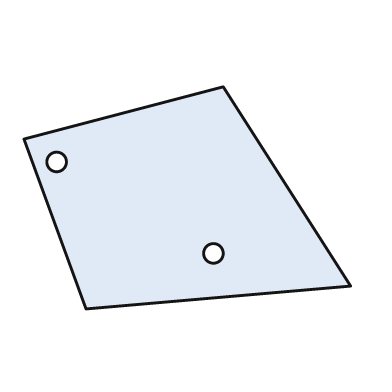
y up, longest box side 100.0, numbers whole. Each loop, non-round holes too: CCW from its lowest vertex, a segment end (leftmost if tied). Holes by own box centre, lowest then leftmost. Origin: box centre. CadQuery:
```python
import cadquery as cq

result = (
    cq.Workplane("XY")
    .moveTo(-31.0, -34.0)
    .lineTo(50.0, -27.0)
    .lineTo(11.0, 34.0)
    .lineTo(-50.0, 18.0)
    .close()
    .moveTo(8.0, -17.0)
    .circle(3.0)
    .moveTo(-40.0, 11.0)
    .circle(3.0)
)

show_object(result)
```